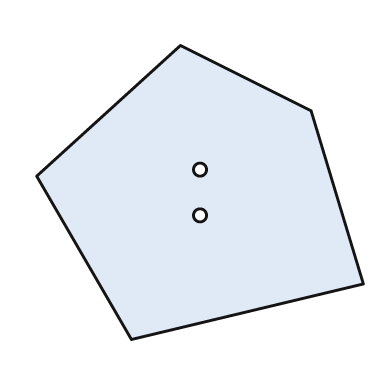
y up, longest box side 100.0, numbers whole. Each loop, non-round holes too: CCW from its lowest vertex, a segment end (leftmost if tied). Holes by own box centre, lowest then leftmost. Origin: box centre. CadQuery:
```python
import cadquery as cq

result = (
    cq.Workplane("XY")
    .moveTo(-21.0, -45.0)
    .lineTo(50.0, -28.0)
    .lineTo(34.0, 25.0)
    .lineTo(-6.0, 45.0)
    .lineTo(-50.0, 5.0)
    .close()
    .moveTo(0.0, -7.0)
    .circle(2.0)
    .moveTo(0.0, 7.0)
    .circle(2.0)
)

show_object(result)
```